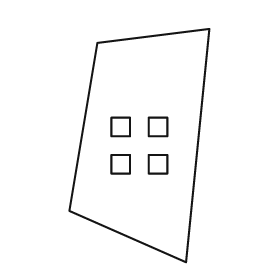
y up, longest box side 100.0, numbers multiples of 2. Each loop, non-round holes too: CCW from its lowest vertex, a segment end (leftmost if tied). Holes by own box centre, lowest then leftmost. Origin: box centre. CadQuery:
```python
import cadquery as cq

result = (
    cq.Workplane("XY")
    .moveTo(20.0, -50.0)
    .lineTo(30.0, 50.0)
    .lineTo(-18.0, 44.0)
    .lineTo(-30.0, -28.0)
    .close()
    .moveTo(-12.0, -12.0)
    .lineTo(-4.0, -12.0)
    .lineTo(-4.0, -4.0)
    .lineTo(-12.0, -4.0)
    .close()
    .moveTo(4.0, -12.0)
    .lineTo(12.0, -12.0)
    .lineTo(12.0, -4.0)
    .lineTo(4.0, -4.0)
    .close()
    .moveTo(-12.0, 4.0)
    .lineTo(-4.0, 4.0)
    .lineTo(-4.0, 12.0)
    .lineTo(-12.0, 12.0)
    .close()
    .moveTo(4.0, 4.0)
    .lineTo(12.0, 4.0)
    .lineTo(12.0, 12.0)
    .lineTo(4.0, 12.0)
    .close()
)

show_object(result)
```